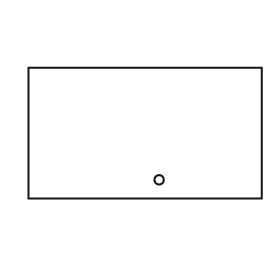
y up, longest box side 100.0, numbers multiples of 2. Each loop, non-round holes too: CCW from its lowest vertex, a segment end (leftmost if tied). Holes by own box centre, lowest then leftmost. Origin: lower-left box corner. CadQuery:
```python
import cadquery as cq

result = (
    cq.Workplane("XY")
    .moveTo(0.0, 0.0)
    .lineTo(100.0, 0.0)
    .lineTo(100.0, 56.0)
    .lineTo(0.0, 56.0)
    .close()
    .moveTo(56.0, 8.0)
    .circle(2.0)
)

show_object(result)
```